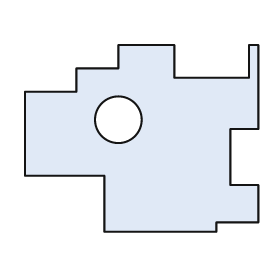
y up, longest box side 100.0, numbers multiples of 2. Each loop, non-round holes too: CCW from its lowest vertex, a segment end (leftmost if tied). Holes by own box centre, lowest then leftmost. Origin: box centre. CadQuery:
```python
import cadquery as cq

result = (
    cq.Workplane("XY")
    .moveTo(-16.0, -40.0)
    .lineTo(32.0, -40.0)
    .lineTo(32.0, -36.0)
    .lineTo(50.0, -36.0)
    .lineTo(50.0, -20.0)
    .lineTo(38.0, -20.0)
    .lineTo(38.0, 4.0)
    .lineTo(50.0, 4.0)
    .lineTo(50.0, 40.0)
    .lineTo(46.0, 40.0)
    .lineTo(46.0, 26.0)
    .lineTo(14.0, 26.0)
    .lineTo(14.0, 40.0)
    .lineTo(-10.0, 40.0)
    .lineTo(-10.0, 30.0)
    .lineTo(-28.0, 30.0)
    .lineTo(-28.0, 20.0)
    .lineTo(-50.0, 20.0)
    .lineTo(-50.0, -16.0)
    .lineTo(-16.0, -16.0)
    .close()
    .moveTo(-10.0, 8.0)
    .circle(10.0)
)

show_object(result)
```